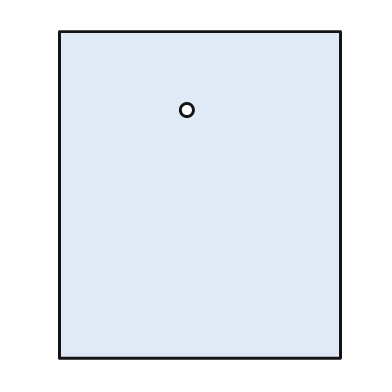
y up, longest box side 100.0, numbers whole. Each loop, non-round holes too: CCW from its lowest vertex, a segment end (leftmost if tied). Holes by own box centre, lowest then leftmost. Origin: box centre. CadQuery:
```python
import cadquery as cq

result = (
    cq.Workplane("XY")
    .moveTo(-43.0, -50.0)
    .lineTo(43.0, -50.0)
    .lineTo(43.0, 50.0)
    .lineTo(-43.0, 50.0)
    .close()
    .moveTo(-4.0, 26.0)
    .circle(2.0)
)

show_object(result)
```